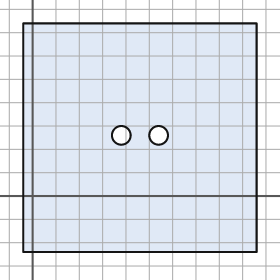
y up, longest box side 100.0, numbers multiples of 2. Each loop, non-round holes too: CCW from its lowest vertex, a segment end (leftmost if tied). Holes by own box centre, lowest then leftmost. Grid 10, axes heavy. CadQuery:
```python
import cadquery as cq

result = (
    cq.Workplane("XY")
    .moveTo(-4.0, -24.0)
    .lineTo(96.0, -24.0)
    .lineTo(96.0, 74.0)
    .lineTo(-4.0, 74.0)
    .close()
    .moveTo(38.0, 26.0)
    .circle(4.0)
    .moveTo(54.0, 26.0)
    .circle(4.0)
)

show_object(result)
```